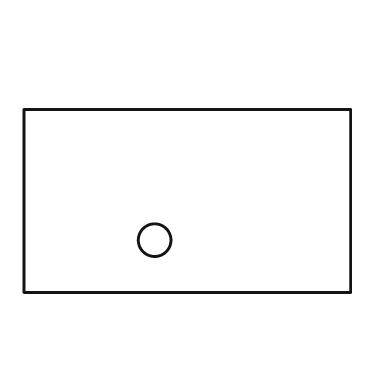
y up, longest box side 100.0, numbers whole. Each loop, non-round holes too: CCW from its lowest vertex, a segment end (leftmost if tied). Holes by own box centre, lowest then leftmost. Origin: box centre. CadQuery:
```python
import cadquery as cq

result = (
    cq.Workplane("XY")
    .moveTo(-50.0, -28.0)
    .lineTo(50.0, -28.0)
    .lineTo(50.0, 28.0)
    .lineTo(-50.0, 28.0)
    .close()
    .moveTo(-10.0, -12.0)
    .circle(5.0)
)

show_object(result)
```